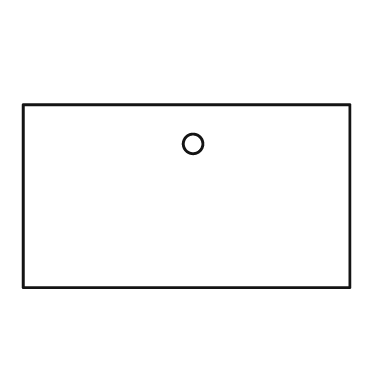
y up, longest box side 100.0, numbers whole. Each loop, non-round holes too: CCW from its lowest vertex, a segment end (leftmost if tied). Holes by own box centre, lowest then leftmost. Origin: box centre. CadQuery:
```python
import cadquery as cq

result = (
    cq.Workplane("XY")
    .moveTo(-50.0, -28.0)
    .lineTo(50.0, -28.0)
    .lineTo(50.0, 28.0)
    .lineTo(-50.0, 28.0)
    .close()
    .moveTo(2.0, 16.0)
    .circle(3.0)
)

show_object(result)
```